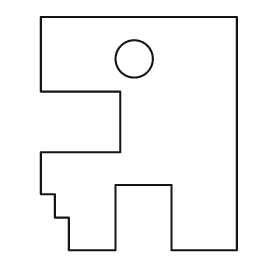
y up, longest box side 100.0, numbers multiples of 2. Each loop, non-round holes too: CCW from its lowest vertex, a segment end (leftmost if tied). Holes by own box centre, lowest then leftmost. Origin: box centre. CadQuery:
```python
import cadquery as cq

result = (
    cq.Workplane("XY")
    .moveTo(-30.0, -50.0)
    .lineTo(-10.0, -50.0)
    .lineTo(-10.0, -22.0)
    .lineTo(14.0, -22.0)
    .lineTo(14.0, -50.0)
    .lineTo(42.0, -50.0)
    .lineTo(42.0, 50.0)
    .lineTo(-42.0, 50.0)
    .lineTo(-42.0, 18.0)
    .lineTo(-8.0, 18.0)
    .lineTo(-8.0, -8.0)
    .lineTo(-42.0, -8.0)
    .lineTo(-42.0, -26.0)
    .lineTo(-36.0, -26.0)
    .lineTo(-36.0, -36.0)
    .lineTo(-30.0, -36.0)
    .close()
    .moveTo(-2.0, 32.0)
    .circle(8.0)
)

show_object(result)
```